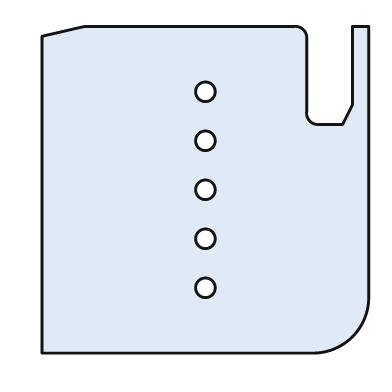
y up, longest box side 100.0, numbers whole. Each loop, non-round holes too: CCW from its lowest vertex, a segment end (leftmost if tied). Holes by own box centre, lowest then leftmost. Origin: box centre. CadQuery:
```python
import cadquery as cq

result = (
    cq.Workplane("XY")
    .moveTo(-50.0, -50.0)
    .lineTo(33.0, -50.0)
    .threePointArc((45.0, -45.0), (50.0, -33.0))
    .lineTo(50.0, 50.0)
    .lineTo(45.0, 50.0)
    .lineTo(45.0, 26.0)
    .lineTo(42.0, 20.0)
    .lineTo(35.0, 20.0)
    .threePointArc((32.0, 21.0), (31.0, 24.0))
    .lineTo(31.0, 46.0)
    .threePointArc((30.0, 49.0), (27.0, 50.0))
    .lineTo(-37.0, 50.0)
    .lineTo(-50.0, 47.0)
    .close()
    .moveTo(0.0, -30.0)
    .circle(3.0)
    .moveTo(0.0, -15.0)
    .circle(3.0)
    .moveTo(0.0, 0.0)
    .circle(3.0)
    .moveTo(0.0, 15.0)
    .circle(3.0)
    .moveTo(0.0, 30.0)
    .circle(3.0)
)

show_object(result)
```